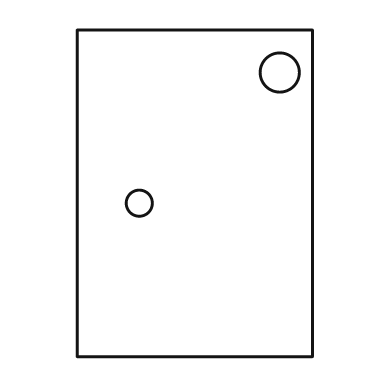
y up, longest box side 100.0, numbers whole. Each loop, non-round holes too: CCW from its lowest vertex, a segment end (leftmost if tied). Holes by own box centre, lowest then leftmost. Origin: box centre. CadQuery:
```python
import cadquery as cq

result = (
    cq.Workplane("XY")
    .moveTo(-36.0, -50.0)
    .lineTo(36.0, -50.0)
    .lineTo(36.0, 50.0)
    .lineTo(-36.0, 50.0)
    .close()
    .moveTo(-17.0, -3.0)
    .circle(4.0)
    .moveTo(26.0, 37.0)
    .circle(6.0)
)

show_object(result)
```